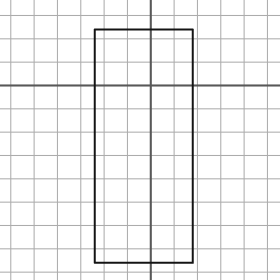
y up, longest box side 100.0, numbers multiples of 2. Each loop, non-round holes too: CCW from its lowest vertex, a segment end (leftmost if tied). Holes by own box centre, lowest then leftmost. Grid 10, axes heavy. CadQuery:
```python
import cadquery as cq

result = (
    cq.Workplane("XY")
    .moveTo(-24.0, -76.0)
    .lineTo(18.0, -76.0)
    .lineTo(18.0, 24.0)
    .lineTo(-24.0, 24.0)
    .close()
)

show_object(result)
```